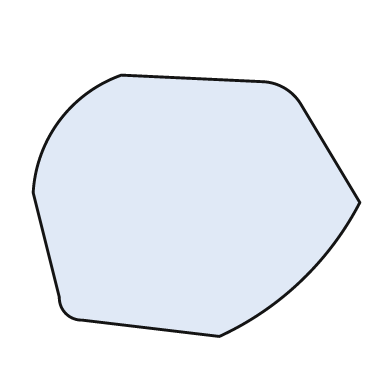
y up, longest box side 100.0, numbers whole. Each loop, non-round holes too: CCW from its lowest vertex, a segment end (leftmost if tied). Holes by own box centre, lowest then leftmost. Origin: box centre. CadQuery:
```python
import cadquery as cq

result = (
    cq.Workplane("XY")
    .moveTo(7.0, -40.0)
    .threePointArc((32.0, -23.0), (50.0, 1.0))
    .lineTo(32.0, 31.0)
    .threePointArc((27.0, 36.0), (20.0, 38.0))
    .lineTo(-23.0, 40.0)
    .threePointArc((-42.0, 26.0), (-50.0, 4.0))
    .lineTo(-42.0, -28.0)
    .threePointArc((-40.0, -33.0), (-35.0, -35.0))
    .close()
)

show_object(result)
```